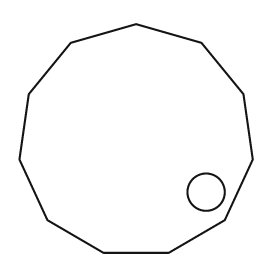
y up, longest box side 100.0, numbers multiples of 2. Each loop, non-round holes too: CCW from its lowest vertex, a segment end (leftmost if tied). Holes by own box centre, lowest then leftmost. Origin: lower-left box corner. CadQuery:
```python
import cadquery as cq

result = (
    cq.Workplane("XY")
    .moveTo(36.0, 0.0)
    .lineTo(64.0, 0.0)
    .lineTo(88.0, 14.0)
    .lineTo(100.0, 40.0)
    .lineTo(96.0, 68.0)
    .lineTo(78.0, 90.0)
    .lineTo(50.0, 98.0)
    .lineTo(22.0, 90.0)
    .lineTo(4.0, 68.0)
    .lineTo(0.0, 40.0)
    .lineTo(12.0, 14.0)
    .close()
    .moveTo(80.0, 26.0)
    .circle(8.0)
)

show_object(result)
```